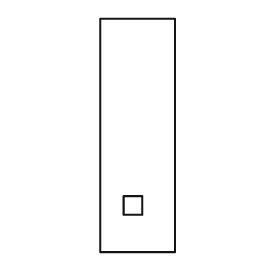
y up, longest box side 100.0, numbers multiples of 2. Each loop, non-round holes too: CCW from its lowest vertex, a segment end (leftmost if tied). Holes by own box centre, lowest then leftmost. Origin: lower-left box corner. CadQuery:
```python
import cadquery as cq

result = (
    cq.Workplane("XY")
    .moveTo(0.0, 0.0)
    .lineTo(32.0, 0.0)
    .lineTo(32.0, 100.0)
    .lineTo(0.0, 100.0)
    .close()
    .moveTo(10.0, 16.0)
    .lineTo(18.0, 16.0)
    .lineTo(18.0, 24.0)
    .lineTo(10.0, 24.0)
    .close()
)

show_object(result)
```